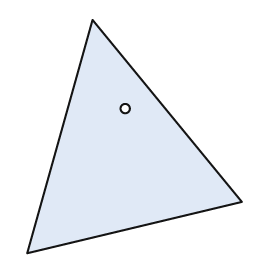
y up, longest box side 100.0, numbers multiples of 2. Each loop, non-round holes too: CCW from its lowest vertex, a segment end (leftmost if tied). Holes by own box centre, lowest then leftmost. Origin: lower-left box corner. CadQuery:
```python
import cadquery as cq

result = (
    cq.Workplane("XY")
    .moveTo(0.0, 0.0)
    .lineTo(92.0, 22.0)
    .lineTo(28.0, 100.0)
    .close()
    .moveTo(42.0, 62.0)
    .circle(2.0)
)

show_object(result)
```